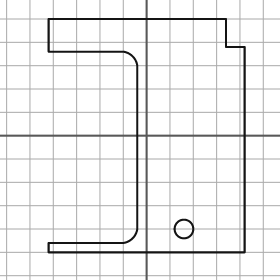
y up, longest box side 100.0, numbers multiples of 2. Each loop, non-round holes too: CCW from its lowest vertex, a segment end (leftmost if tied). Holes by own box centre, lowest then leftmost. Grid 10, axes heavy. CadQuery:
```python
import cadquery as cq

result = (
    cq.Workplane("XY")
    .moveTo(-42.0, -50.0)
    .lineTo(42.0, -50.0)
    .lineTo(42.0, 38.0)
    .lineTo(34.0, 38.0)
    .lineTo(34.0, 50.0)
    .lineTo(-42.0, 50.0)
    .lineTo(-42.0, 36.0)
    .lineTo(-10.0, 36.0)
    .threePointArc((-6.0, 34.0), (-4.0, 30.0))
    .lineTo(-4.0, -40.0)
    .threePointArc((-6.0, -44.0), (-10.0, -46.0))
    .lineTo(-42.0, -46.0)
    .close()
    .moveTo(16.0, -40.0)
    .circle(4.0)
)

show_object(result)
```